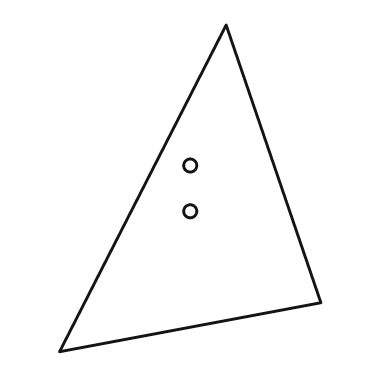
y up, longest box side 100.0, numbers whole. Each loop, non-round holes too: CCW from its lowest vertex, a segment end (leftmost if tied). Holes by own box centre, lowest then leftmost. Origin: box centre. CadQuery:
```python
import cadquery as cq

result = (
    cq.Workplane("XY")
    .moveTo(-40.0, -50.0)
    .lineTo(40.0, -35.0)
    .lineTo(11.0, 50.0)
    .close()
    .moveTo(0.0, -7.0)
    .circle(2.0)
    .moveTo(0.0, 7.0)
    .circle(2.0)
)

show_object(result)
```